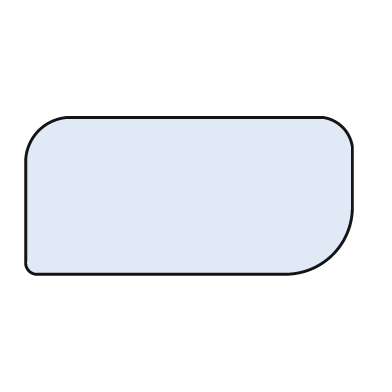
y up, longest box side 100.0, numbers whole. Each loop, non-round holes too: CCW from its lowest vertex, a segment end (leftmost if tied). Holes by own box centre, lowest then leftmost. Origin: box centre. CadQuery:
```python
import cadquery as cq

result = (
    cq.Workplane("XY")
    .moveTo(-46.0, -24.0)
    .lineTo(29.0, -24.0)
    .threePointArc((44.0, -18.0), (50.0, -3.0))
    .lineTo(50.0, 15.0)
    .threePointArc((47.0, 21.0), (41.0, 24.0))
    .lineTo(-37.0, 24.0)
    .threePointArc((-46.0, 20.0), (-50.0, 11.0))
    .lineTo(-50.0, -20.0)
    .threePointArc((-49.0, -23.0), (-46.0, -24.0))
    .close()
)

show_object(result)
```